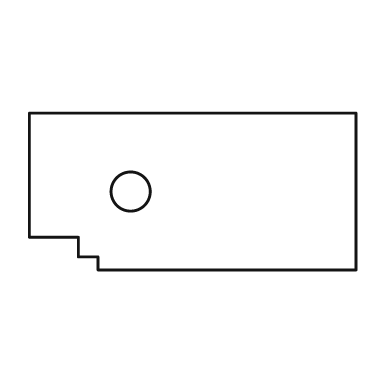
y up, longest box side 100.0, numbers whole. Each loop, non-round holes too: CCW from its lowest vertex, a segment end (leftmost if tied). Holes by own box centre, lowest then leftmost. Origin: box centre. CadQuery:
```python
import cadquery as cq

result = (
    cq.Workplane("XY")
    .moveTo(-29.0, -24.0)
    .lineTo(50.0, -24.0)
    .lineTo(50.0, 24.0)
    .lineTo(-50.0, 24.0)
    .lineTo(-50.0, -14.0)
    .lineTo(-35.0, -14.0)
    .lineTo(-35.0, -20.0)
    .lineTo(-29.0, -20.0)
    .close()
    .moveTo(-19.0, 0.0)
    .circle(6.0)
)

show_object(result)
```